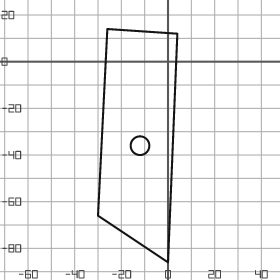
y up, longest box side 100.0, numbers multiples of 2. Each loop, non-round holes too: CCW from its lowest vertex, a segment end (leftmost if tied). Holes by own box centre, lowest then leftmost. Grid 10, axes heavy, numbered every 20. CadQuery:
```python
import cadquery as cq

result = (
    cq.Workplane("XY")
    .moveTo(0.0, -86.0)
    .lineTo(4.0, 12.0)
    .lineTo(-26.0, 14.0)
    .lineTo(-30.0, -66.0)
    .close()
    .moveTo(-12.0, -36.0)
    .circle(4.0)
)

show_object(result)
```